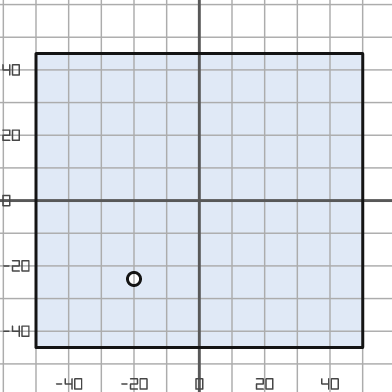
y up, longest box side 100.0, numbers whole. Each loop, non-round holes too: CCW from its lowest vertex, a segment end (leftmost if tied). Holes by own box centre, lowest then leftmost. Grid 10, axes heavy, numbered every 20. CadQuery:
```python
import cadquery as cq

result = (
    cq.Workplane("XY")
    .moveTo(-50.0, -45.0)
    .lineTo(50.0, -45.0)
    .lineTo(50.0, 45.0)
    .lineTo(-50.0, 45.0)
    .close()
    .moveTo(-20.0, -24.0)
    .circle(2.0)
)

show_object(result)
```